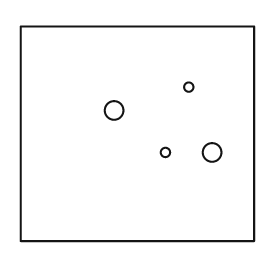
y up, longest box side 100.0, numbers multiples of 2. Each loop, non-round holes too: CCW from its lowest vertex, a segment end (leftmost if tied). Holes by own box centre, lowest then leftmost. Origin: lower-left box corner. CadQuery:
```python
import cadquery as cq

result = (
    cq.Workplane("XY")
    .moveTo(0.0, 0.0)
    .lineTo(100.0, 0.0)
    .lineTo(100.0, 92.0)
    .lineTo(0.0, 92.0)
    .close()
    .moveTo(62.0, 38.0)
    .circle(2.0)
    .moveTo(82.0, 38.0)
    .circle(4.0)
    .moveTo(40.0, 56.0)
    .circle(4.0)
    .moveTo(72.0, 66.0)
    .circle(2.0)
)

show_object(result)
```